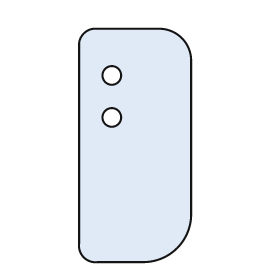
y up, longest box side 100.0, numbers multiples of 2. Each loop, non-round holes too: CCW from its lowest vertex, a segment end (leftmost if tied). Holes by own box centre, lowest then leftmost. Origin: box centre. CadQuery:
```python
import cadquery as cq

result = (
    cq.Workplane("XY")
    .moveTo(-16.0, -50.0)
    .lineTo(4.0, -50.0)
    .threePointArc((18.0, -44.0), (24.0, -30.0))
    .lineTo(24.0, 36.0)
    .threePointArc((20.0, 46.0), (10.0, 50.0))
    .lineTo(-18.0, 50.0)
    .threePointArc((-22.0, 48.0), (-24.0, 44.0))
    .lineTo(-24.0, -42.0)
    .threePointArc((-22.0, -48.0), (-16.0, -50.0))
    .close()
    .moveTo(-10.0, 12.0)
    .circle(4.0)
    .moveTo(-10.0, 30.0)
    .circle(4.0)
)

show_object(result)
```